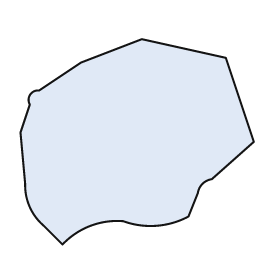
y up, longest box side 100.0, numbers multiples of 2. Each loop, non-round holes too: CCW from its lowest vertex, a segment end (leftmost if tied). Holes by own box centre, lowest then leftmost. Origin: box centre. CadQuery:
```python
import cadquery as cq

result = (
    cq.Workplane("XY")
    .moveTo(-32.0, -44.0)
    .threePointArc((-20.0, -36.0), (-6.0, -34.0))
    .threePointArc((8.0, -36.0), (22.0, -32.0))
    .lineTo(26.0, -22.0)
    .threePointArc((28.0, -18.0), (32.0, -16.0))
    .lineTo(50.0, 0.0)
    .lineTo(38.0, 36.0)
    .lineTo(2.0, 44.0)
    .lineTo(-24.0, 34.0)
    .lineTo(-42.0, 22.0)
    .threePointArc((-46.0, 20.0), (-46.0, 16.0))
    .lineTo(-50.0, 4.0)
    .lineTo(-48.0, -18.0)
    .threePointArc((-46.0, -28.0), (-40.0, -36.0))
    .close()
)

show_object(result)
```